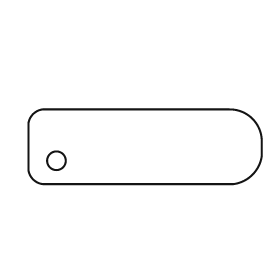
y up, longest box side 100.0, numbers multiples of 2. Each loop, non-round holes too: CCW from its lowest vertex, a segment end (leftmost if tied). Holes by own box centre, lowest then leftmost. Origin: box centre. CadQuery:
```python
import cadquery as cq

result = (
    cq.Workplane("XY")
    .moveTo(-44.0, -16.0)
    .lineTo(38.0, -16.0)
    .threePointArc((46.0, -12.0), (50.0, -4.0))
    .lineTo(50.0, 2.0)
    .threePointArc((46.0, 12.0), (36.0, 16.0))
    .lineTo(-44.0, 16.0)
    .threePointArc((-48.0, 14.0), (-50.0, 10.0))
    .lineTo(-50.0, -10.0)
    .threePointArc((-48.0, -14.0), (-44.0, -16.0))
    .close()
    .moveTo(-38.0, -6.0)
    .circle(4.0)
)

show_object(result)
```